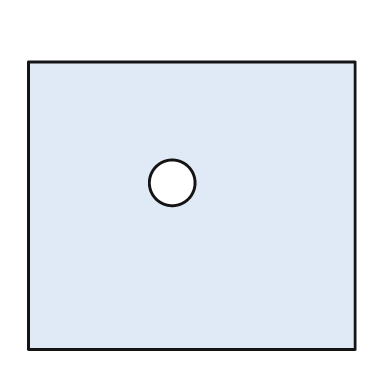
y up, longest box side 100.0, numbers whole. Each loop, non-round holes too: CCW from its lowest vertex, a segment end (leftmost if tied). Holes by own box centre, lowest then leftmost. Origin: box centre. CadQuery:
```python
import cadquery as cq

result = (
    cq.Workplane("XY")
    .moveTo(-50.0, -44.0)
    .lineTo(50.0, -44.0)
    .lineTo(50.0, 44.0)
    .lineTo(-50.0, 44.0)
    .close()
    .moveTo(-6.0, 7.0)
    .circle(7.0)
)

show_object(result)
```